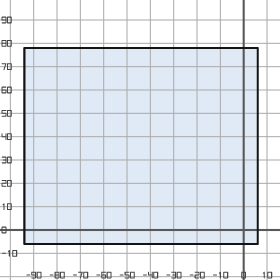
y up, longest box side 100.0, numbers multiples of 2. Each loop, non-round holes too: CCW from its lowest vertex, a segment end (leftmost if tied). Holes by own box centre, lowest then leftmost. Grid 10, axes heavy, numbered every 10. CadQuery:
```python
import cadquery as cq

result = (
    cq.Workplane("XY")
    .moveTo(-94.0, -6.0)
    .lineTo(6.0, -6.0)
    .lineTo(6.0, 78.0)
    .lineTo(-94.0, 78.0)
    .close()
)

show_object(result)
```